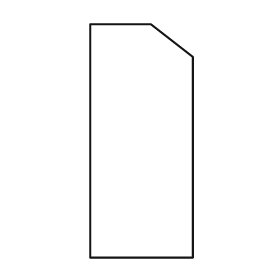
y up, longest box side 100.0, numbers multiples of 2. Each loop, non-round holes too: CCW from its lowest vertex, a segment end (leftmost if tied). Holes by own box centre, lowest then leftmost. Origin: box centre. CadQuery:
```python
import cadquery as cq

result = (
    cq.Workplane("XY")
    .moveTo(-22.0, -50.0)
    .lineTo(22.0, -50.0)
    .lineTo(22.0, 36.0)
    .lineTo(4.0, 50.0)
    .lineTo(-22.0, 50.0)
    .close()
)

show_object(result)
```